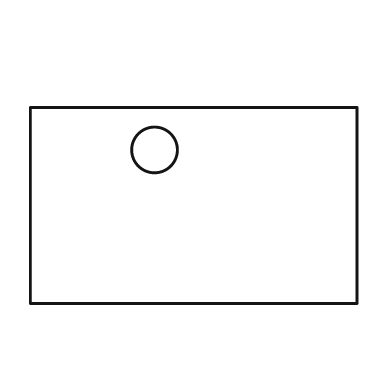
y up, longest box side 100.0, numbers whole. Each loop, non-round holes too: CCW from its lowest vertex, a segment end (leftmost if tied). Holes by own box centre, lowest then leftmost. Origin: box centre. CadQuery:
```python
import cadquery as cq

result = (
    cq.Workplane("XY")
    .moveTo(-50.0, -30.0)
    .lineTo(50.0, -30.0)
    .lineTo(50.0, 30.0)
    .lineTo(-50.0, 30.0)
    .close()
    .moveTo(-12.0, 17.0)
    .circle(7.0)
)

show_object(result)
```